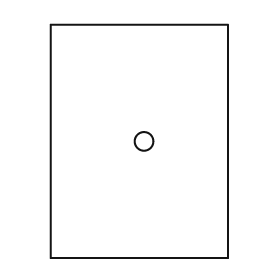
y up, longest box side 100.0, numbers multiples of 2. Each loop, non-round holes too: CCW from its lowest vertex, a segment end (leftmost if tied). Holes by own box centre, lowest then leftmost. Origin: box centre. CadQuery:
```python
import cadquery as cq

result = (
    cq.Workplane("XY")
    .moveTo(-38.0, -50.0)
    .lineTo(38.0, -50.0)
    .lineTo(38.0, 50.0)
    .lineTo(-38.0, 50.0)
    .close()
    .moveTo(2.0, 0.0)
    .circle(4.0)
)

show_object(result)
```